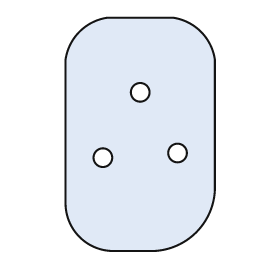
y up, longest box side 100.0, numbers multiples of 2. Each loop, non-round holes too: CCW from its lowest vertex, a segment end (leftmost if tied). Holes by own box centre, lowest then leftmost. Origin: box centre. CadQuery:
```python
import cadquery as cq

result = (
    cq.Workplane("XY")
    .moveTo(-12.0, -50.0)
    .lineTo(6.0, -50.0)
    .threePointArc((24.0, -42.0), (32.0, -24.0))
    .lineTo(32.0, 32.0)
    .threePointArc((26.0, 44.0), (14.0, 50.0))
    .lineTo(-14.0, 50.0)
    .threePointArc((-26.0, 44.0), (-32.0, 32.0))
    .lineTo(-32.0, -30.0)
    .threePointArc((-26.0, -44.0), (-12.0, -50.0))
    .close()
    .moveTo(-16.0, -10.0)
    .circle(4.0)
    .moveTo(16.0, -8.0)
    .circle(4.0)
    .moveTo(0.0, 18.0)
    .circle(4.0)
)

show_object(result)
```